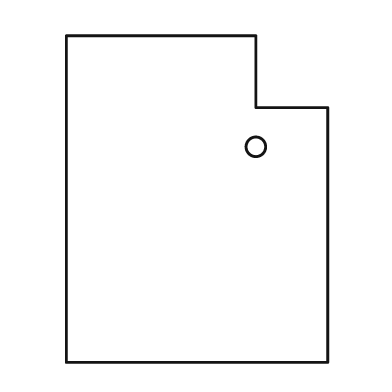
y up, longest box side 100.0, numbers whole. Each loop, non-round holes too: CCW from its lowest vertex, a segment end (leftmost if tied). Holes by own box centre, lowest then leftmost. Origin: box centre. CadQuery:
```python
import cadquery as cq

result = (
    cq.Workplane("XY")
    .moveTo(-40.0, -50.0)
    .lineTo(40.0, -50.0)
    .lineTo(40.0, 28.0)
    .lineTo(18.0, 28.0)
    .lineTo(18.0, 50.0)
    .lineTo(-40.0, 50.0)
    .close()
    .moveTo(18.0, 16.0)
    .circle(3.0)
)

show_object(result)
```